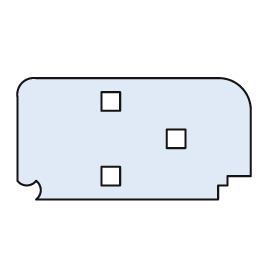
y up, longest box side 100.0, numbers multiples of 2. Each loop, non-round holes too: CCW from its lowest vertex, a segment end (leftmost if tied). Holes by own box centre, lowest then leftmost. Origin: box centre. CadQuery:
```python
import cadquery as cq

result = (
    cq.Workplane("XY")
    .moveTo(-42.0, -26.0)
    .lineTo(36.0, -26.0)
    .lineTo(36.0, -20.0)
    .lineTo(40.0, -20.0)
    .lineTo(40.0, -16.0)
    .lineTo(50.0, -16.0)
    .lineTo(50.0, 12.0)
    .threePointArc((46.0, 22.0), (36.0, 26.0))
    .lineTo(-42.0, 26.0)
    .threePointArc((-48.0, 24.0), (-50.0, 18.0))
    .lineTo(-50.0, -18.0)
    .threePointArc((-46.0, -20.0), (-42.0, -18.0))
    .threePointArc((-40.0, -22.0), (-42.0, -26.0))
    .close()
    .moveTo(-14.0, -20.0)
    .lineTo(-6.0, -20.0)
    .lineTo(-6.0, -12.0)
    .lineTo(-14.0, -12.0)
    .close()
    .moveTo(14.0, -4.0)
    .lineTo(22.0, -4.0)
    .lineTo(22.0, 4.0)
    .lineTo(14.0, 4.0)
    .close()
    .moveTo(-14.0, 12.0)
    .lineTo(-6.0, 12.0)
    .lineTo(-6.0, 20.0)
    .lineTo(-14.0, 20.0)
    .close()
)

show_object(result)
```